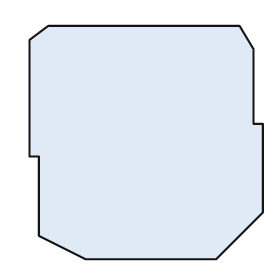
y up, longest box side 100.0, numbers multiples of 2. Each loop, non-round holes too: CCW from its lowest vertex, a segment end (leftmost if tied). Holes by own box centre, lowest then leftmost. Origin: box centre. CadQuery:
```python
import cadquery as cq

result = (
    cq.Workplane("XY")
    .moveTo(-26.0, -50.0)
    .lineTo(30.0, -50.0)
    .lineTo(50.0, -30.0)
    .lineTo(50.0, 8.0)
    .lineTo(46.0, 8.0)
    .lineTo(46.0, 40.0)
    .lineTo(40.0, 50.0)
    .lineTo(-42.0, 50.0)
    .lineTo(-50.0, 44.0)
    .lineTo(-50.0, -6.0)
    .lineTo(-46.0, -6.0)
    .lineTo(-46.0, -40.0)
    .close()
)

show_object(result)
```